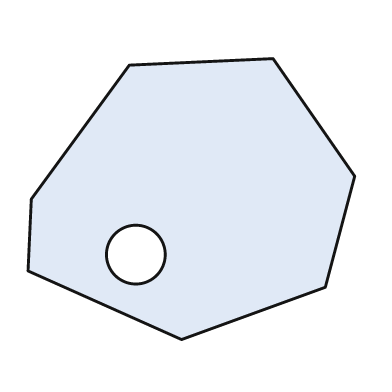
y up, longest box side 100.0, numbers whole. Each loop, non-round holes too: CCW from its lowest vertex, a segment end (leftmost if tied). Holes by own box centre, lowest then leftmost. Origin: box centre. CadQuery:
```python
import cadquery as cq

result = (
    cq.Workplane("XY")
    .moveTo(-3.0, -43.0)
    .lineTo(41.0, -27.0)
    .lineTo(50.0, 7.0)
    .lineTo(25.0, 43.0)
    .lineTo(-19.0, 41.0)
    .lineTo(-49.0, 0.0)
    .lineTo(-50.0, -22.0)
    .close()
    .moveTo(-17.0, -17.0)
    .circle(9.0)
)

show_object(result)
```